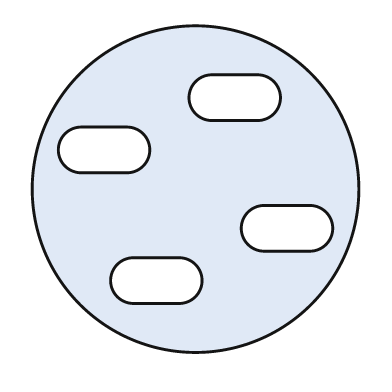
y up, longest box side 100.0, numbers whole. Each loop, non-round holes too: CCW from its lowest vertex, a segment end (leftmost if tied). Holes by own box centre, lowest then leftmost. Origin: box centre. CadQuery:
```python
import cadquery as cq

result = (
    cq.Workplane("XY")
    .moveTo(0.0, 0.0)
    .circle(50.0)
    .moveTo(-19.0, -35.0)
    .lineTo(-5.0, -35.0)
    .threePointArc((2.0, -28.0), (-5.0, -21.0))
    .lineTo(-19.0, -21.0)
    .threePointArc((-26.0, -28.0), (-19.0, -35.0))
    .close()
    .moveTo(21.0, -19.0)
    .lineTo(35.0, -19.0)
    .threePointArc((42.0, -12.0), (35.0, -5.0))
    .lineTo(21.0, -5.0)
    .threePointArc((14.0, -12.0), (21.0, -19.0))
    .close()
    .moveTo(-35.0, 5.0)
    .lineTo(-21.0, 5.0)
    .threePointArc((-14.0, 12.0), (-21.0, 19.0))
    .lineTo(-35.0, 19.0)
    .threePointArc((-42.0, 12.0), (-35.0, 5.0))
    .close()
    .moveTo(5.0, 21.0)
    .lineTo(19.0, 21.0)
    .threePointArc((26.0, 28.0), (19.0, 35.0))
    .lineTo(5.0, 35.0)
    .threePointArc((-2.0, 28.0), (5.0, 21.0))
    .close()
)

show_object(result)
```